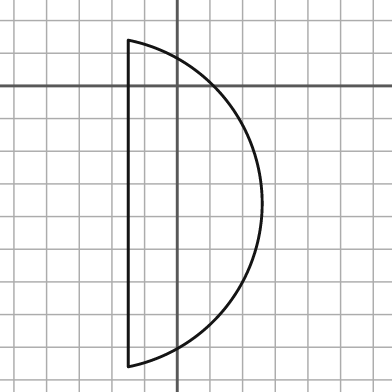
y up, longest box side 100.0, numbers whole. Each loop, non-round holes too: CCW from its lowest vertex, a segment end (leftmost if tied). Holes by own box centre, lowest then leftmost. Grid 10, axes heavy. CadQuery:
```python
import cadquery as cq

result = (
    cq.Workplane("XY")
    .moveTo(-15.0, -86.0)
    .threePointArc((26.0, -36.0), (-15.0, 14.0))
    .close()
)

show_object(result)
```